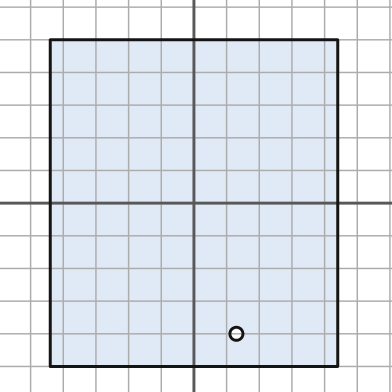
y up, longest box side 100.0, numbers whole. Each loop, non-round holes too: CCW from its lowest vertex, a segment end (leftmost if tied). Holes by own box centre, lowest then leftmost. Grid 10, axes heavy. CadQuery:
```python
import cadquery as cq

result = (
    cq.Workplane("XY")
    .moveTo(-44.0, -50.0)
    .lineTo(44.0, -50.0)
    .lineTo(44.0, 50.0)
    .lineTo(-44.0, 50.0)
    .close()
    .moveTo(13.0, -40.0)
    .circle(2.0)
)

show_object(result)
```